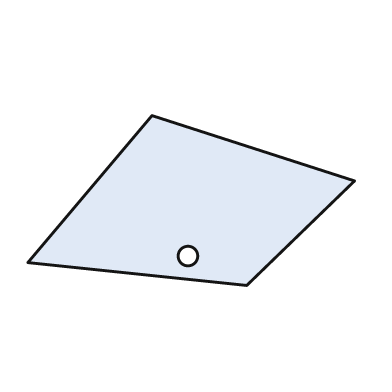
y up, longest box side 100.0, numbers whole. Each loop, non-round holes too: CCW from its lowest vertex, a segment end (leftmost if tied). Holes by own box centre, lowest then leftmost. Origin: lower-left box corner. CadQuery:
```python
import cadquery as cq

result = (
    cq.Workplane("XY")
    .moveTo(67.0, 0.0)
    .lineTo(100.0, 32.0)
    .lineTo(38.0, 52.0)
    .lineTo(0.0, 7.0)
    .close()
    .moveTo(49.0, 9.0)
    .circle(3.0)
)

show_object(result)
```